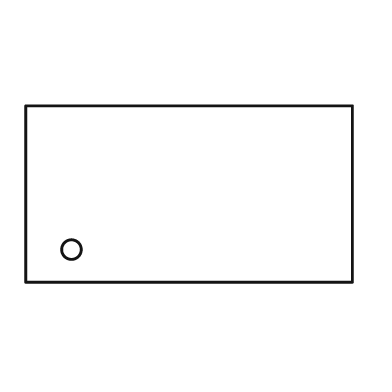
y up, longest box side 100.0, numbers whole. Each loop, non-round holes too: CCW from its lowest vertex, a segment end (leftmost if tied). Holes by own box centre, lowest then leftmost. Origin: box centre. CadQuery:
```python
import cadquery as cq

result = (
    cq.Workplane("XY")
    .moveTo(-50.0, -27.0)
    .lineTo(50.0, -27.0)
    .lineTo(50.0, 27.0)
    .lineTo(-50.0, 27.0)
    .close()
    .moveTo(-36.0, -17.0)
    .circle(3.0)
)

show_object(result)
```